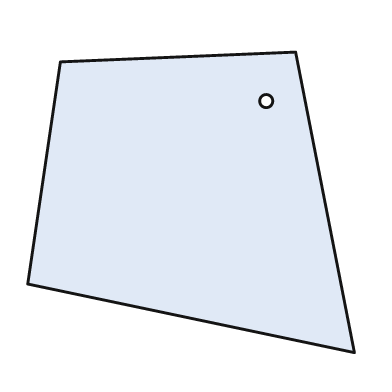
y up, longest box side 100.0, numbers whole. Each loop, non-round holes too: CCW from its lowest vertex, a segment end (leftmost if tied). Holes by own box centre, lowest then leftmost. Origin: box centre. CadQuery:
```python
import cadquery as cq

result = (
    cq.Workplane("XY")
    .moveTo(50.0, -46.0)
    .lineTo(32.0, 46.0)
    .lineTo(-40.0, 43.0)
    .lineTo(-50.0, -25.0)
    .close()
    .moveTo(23.0, 31.0)
    .circle(2.0)
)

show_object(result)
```